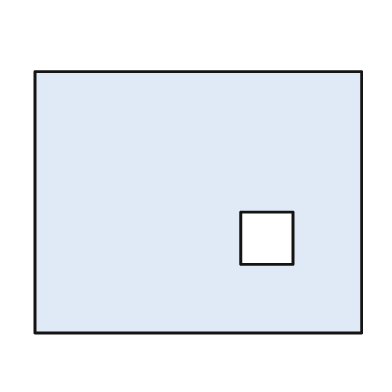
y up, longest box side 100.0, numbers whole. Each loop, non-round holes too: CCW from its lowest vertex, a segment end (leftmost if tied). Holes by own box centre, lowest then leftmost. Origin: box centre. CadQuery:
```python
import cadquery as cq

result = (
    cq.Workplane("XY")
    .moveTo(-50.0, -40.0)
    .lineTo(50.0, -40.0)
    .lineTo(50.0, 40.0)
    .lineTo(-50.0, 40.0)
    .close()
    .moveTo(13.0, -19.0)
    .lineTo(29.0, -19.0)
    .lineTo(29.0, -3.0)
    .lineTo(13.0, -3.0)
    .close()
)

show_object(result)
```